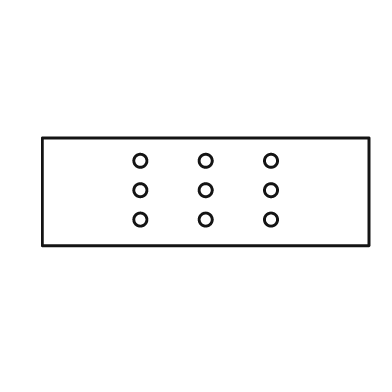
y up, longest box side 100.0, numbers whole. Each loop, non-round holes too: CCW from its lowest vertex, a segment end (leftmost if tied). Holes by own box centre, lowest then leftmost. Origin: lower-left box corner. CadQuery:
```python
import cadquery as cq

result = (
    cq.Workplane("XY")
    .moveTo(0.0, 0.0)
    .lineTo(100.0, 0.0)
    .lineTo(100.0, 33.0)
    .lineTo(0.0, 33.0)
    .close()
    .moveTo(30.0, 8.0)
    .circle(2.0)
    .moveTo(50.0, 8.0)
    .circle(2.0)
    .moveTo(70.0, 8.0)
    .circle(2.0)
    .moveTo(30.0, 17.0)
    .circle(2.0)
    .moveTo(50.0, 17.0)
    .circle(2.0)
    .moveTo(70.0, 17.0)
    .circle(2.0)
    .moveTo(30.0, 26.0)
    .circle(2.0)
    .moveTo(50.0, 26.0)
    .circle(2.0)
    .moveTo(70.0, 26.0)
    .circle(2.0)
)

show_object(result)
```